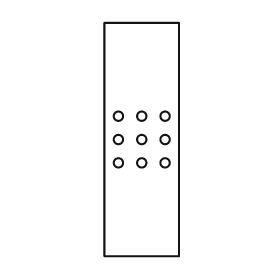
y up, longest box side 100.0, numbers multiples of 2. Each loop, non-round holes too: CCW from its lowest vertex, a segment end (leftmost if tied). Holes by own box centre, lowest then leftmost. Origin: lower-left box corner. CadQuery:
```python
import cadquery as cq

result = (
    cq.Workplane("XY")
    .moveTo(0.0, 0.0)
    .lineTo(32.0, 0.0)
    .lineTo(32.0, 100.0)
    .lineTo(0.0, 100.0)
    .close()
    .moveTo(6.0, 40.0)
    .circle(2.0)
    .moveTo(16.0, 40.0)
    .circle(2.0)
    .moveTo(26.0, 40.0)
    .circle(2.0)
    .moveTo(6.0, 50.0)
    .circle(2.0)
    .moveTo(16.0, 50.0)
    .circle(2.0)
    .moveTo(26.0, 50.0)
    .circle(2.0)
    .moveTo(6.0, 60.0)
    .circle(2.0)
    .moveTo(16.0, 60.0)
    .circle(2.0)
    .moveTo(26.0, 60.0)
    .circle(2.0)
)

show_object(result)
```